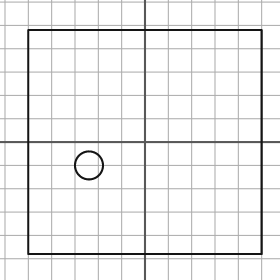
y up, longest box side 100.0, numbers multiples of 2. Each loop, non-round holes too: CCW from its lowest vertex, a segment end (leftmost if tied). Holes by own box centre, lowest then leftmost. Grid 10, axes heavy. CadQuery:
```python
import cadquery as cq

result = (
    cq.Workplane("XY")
    .moveTo(-50.0, -48.0)
    .lineTo(50.0, -48.0)
    .lineTo(50.0, 48.0)
    .lineTo(-50.0, 48.0)
    .close()
    .moveTo(-24.0, -10.0)
    .circle(6.0)
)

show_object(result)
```